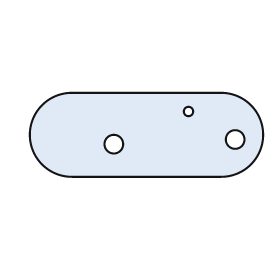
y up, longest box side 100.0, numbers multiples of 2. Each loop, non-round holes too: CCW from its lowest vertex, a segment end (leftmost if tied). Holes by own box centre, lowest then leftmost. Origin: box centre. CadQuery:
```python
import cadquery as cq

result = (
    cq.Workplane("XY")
    .moveTo(-32.0, -18.0)
    .lineTo(32.0, -18.0)
    .threePointArc((50.0, 0.0), (32.0, 18.0))
    .lineTo(-32.0, 18.0)
    .threePointArc((-50.0, 0.0), (-32.0, -18.0))
    .close()
    .moveTo(-14.0, -4.0)
    .circle(4.0)
    .moveTo(38.0, -2.0)
    .circle(4.0)
    .moveTo(18.0, 10.0)
    .circle(2.0)
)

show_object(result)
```